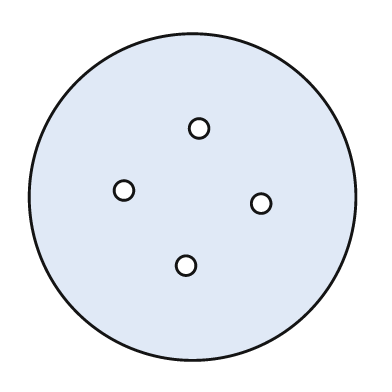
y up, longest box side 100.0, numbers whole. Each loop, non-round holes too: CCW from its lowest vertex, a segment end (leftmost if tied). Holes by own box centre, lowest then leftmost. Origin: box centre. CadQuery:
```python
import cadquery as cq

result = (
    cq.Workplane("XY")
    .moveTo(0.0, 0.0)
    .circle(50.0)
    .moveTo(-2.0, -21.0)
    .circle(3.0)
    .moveTo(21.0, -2.0)
    .circle(3.0)
    .moveTo(-21.0, 2.0)
    .circle(3.0)
    .moveTo(2.0, 21.0)
    .circle(3.0)
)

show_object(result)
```